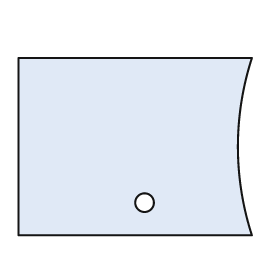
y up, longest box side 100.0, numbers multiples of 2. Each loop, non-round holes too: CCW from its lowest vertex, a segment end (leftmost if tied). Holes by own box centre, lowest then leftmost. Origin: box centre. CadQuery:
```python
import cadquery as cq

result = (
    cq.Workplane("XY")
    .moveTo(-50.0, -38.0)
    .lineTo(50.0, -38.0)
    .threePointArc((44.0, 0.0), (50.0, 38.0))
    .lineTo(-50.0, 38.0)
    .close()
    .moveTo(4.0, -24.0)
    .circle(4.0)
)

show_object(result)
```